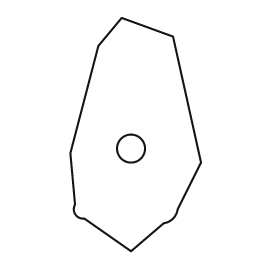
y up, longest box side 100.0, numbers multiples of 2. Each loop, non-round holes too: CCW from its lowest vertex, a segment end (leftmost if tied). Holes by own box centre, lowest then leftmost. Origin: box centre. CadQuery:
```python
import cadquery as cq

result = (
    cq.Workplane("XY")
    .moveTo(-2.0, -50.0)
    .lineTo(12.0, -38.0)
    .threePointArc((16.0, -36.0), (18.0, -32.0))
    .lineTo(28.0, -12.0)
    .lineTo(16.0, 42.0)
    .lineTo(-6.0, 50.0)
    .lineTo(-16.0, 38.0)
    .lineTo(-28.0, -8.0)
    .lineTo(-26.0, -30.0)
    .threePointArc((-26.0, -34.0), (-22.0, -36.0))
    .close()
    .moveTo(-2.0, -6.0)
    .circle(6.0)
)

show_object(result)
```